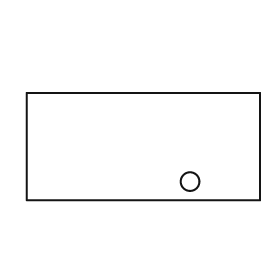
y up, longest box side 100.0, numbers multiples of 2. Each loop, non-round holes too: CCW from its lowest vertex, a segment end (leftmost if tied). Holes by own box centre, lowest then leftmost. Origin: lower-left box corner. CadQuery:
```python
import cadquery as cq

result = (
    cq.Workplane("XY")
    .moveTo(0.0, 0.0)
    .lineTo(100.0, 0.0)
    .lineTo(100.0, 46.0)
    .lineTo(0.0, 46.0)
    .close()
    .moveTo(70.0, 8.0)
    .circle(4.0)
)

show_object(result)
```